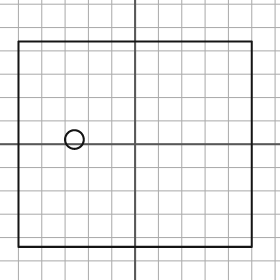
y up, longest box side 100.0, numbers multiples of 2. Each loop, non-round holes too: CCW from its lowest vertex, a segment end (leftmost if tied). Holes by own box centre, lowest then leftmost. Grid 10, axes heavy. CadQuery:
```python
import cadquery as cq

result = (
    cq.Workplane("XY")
    .moveTo(-50.0, -44.0)
    .lineTo(50.0, -44.0)
    .lineTo(50.0, 44.0)
    .lineTo(-50.0, 44.0)
    .close()
    .moveTo(-26.0, 2.0)
    .circle(4.0)
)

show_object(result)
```